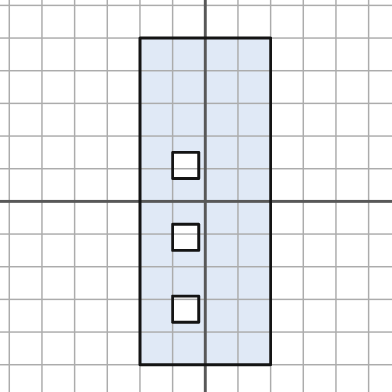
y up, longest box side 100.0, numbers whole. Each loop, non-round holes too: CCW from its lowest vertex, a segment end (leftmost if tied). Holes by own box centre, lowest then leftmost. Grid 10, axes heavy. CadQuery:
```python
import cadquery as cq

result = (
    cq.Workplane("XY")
    .moveTo(-20.0, -50.0)
    .lineTo(20.0, -50.0)
    .lineTo(20.0, 50.0)
    .lineTo(-20.0, 50.0)
    .close()
    .moveTo(-10.0, -37.0)
    .lineTo(-2.0, -37.0)
    .lineTo(-2.0, -29.0)
    .lineTo(-10.0, -29.0)
    .close()
    .moveTo(-10.0, -15.0)
    .lineTo(-2.0, -15.0)
    .lineTo(-2.0, -7.0)
    .lineTo(-10.0, -7.0)
    .close()
    .moveTo(-10.0, 7.0)
    .lineTo(-2.0, 7.0)
    .lineTo(-2.0, 15.0)
    .lineTo(-10.0, 15.0)
    .close()
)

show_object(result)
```